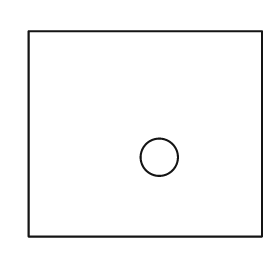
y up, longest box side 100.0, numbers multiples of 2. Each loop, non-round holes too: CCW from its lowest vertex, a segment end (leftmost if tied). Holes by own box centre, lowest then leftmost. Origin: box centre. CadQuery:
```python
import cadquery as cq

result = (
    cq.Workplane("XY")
    .moveTo(-50.0, -44.0)
    .lineTo(50.0, -44.0)
    .lineTo(50.0, 44.0)
    .lineTo(-50.0, 44.0)
    .close()
    .moveTo(6.0, -10.0)
    .circle(8.0)
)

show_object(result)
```